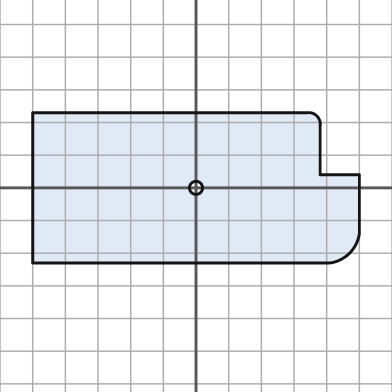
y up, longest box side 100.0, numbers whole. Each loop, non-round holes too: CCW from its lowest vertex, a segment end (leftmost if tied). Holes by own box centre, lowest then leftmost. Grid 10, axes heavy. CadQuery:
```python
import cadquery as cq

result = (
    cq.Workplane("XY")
    .moveTo(-50.0, -23.0)
    .lineTo(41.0, -23.0)
    .threePointArc((47.0, -20.0), (50.0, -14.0))
    .lineTo(50.0, 4.0)
    .lineTo(38.0, 4.0)
    .lineTo(38.0, 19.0)
    .threePointArc((37.0, 22.0), (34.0, 23.0))
    .lineTo(-50.0, 23.0)
    .close()
    .moveTo(0.0, 0.0)
    .circle(2.0)
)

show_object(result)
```